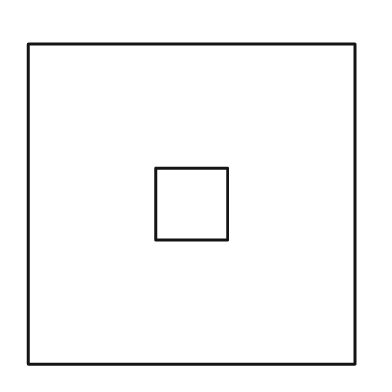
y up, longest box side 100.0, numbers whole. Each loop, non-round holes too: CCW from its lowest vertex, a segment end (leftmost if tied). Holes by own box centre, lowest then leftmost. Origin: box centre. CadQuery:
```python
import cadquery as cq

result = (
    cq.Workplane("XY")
    .moveTo(-50.0, -49.0)
    .lineTo(50.0, -49.0)
    .lineTo(50.0, 49.0)
    .lineTo(-50.0, 49.0)
    .close()
    .moveTo(-11.0, -11.0)
    .lineTo(11.0, -11.0)
    .lineTo(11.0, 11.0)
    .lineTo(-11.0, 11.0)
    .close()
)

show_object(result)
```